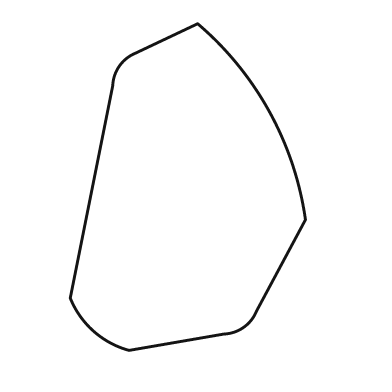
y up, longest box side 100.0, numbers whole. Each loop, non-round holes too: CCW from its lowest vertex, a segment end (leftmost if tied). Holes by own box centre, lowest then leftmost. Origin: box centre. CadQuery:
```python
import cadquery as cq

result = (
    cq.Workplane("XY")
    .moveTo(-18.0, -50.0)
    .lineTo(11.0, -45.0)
    .threePointArc((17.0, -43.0), (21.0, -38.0))
    .lineTo(36.0, -10.0)
    .threePointArc((25.0, 23.0), (3.0, 50.0))
    .lineTo(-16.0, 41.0)
    .threePointArc((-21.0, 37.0), (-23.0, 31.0))
    .lineTo(-36.0, -34.0)
    .threePointArc((-29.0, -44.0), (-18.0, -50.0))
    .close()
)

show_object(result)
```